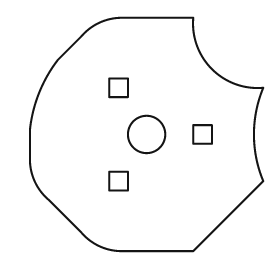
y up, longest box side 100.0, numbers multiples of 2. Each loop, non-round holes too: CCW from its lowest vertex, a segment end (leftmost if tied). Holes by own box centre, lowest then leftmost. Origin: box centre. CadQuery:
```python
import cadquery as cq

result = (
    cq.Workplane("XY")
    .moveTo(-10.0, -50.0)
    .lineTo(20.0, -50.0)
    .lineTo(50.0, -20.0)
    .threePointArc((46.0, 0.0), (50.0, 20.0))
    .threePointArc((28.0, 28.0), (20.0, 50.0))
    .lineTo(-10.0, 50.0)
    .threePointArc((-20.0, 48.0), (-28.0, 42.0))
    .lineTo(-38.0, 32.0)
    .threePointArc((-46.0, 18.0), (-50.0, 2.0))
    .lineTo(-50.0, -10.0)
    .threePointArc((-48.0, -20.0), (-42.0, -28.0))
    .lineTo(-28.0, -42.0)
    .threePointArc((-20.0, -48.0), (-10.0, -50.0))
    .close()
    .moveTo(-16.0, -24.0)
    .lineTo(-8.0, -24.0)
    .lineTo(-8.0, -16.0)
    .lineTo(-16.0, -16.0)
    .close()
    .moveTo(0.0, 0.0)
    .circle(8.0)
    .moveTo(20.0, -4.0)
    .lineTo(28.0, -4.0)
    .lineTo(28.0, 4.0)
    .lineTo(20.0, 4.0)
    .close()
    .moveTo(-16.0, 16.0)
    .lineTo(-8.0, 16.0)
    .lineTo(-8.0, 24.0)
    .lineTo(-16.0, 24.0)
    .close()
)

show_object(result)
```